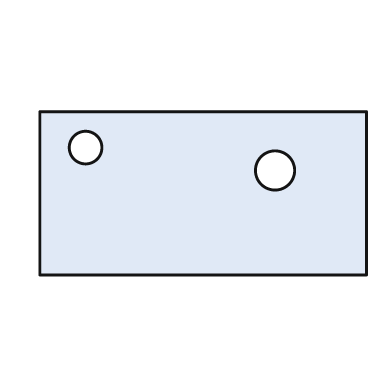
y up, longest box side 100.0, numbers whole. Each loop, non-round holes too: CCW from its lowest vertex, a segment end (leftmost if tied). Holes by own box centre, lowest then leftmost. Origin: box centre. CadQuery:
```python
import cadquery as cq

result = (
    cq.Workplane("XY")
    .moveTo(-50.0, -25.0)
    .lineTo(50.0, -25.0)
    .lineTo(50.0, 25.0)
    .lineTo(-50.0, 25.0)
    .close()
    .moveTo(22.0, 7.0)
    .circle(6.0)
    .moveTo(-36.0, 14.0)
    .circle(5.0)
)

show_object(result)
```